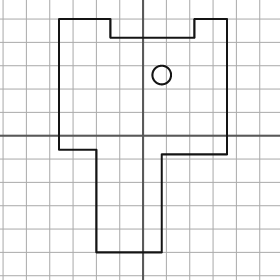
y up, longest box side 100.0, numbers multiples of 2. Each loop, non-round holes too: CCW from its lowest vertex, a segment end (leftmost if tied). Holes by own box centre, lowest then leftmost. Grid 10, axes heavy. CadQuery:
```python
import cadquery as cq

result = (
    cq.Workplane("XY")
    .moveTo(-20.0, -50.0)
    .lineTo(8.0, -50.0)
    .lineTo(8.0, -8.0)
    .lineTo(36.0, -8.0)
    .lineTo(36.0, 50.0)
    .lineTo(22.0, 50.0)
    .lineTo(22.0, 42.0)
    .lineTo(-14.0, 42.0)
    .lineTo(-14.0, 50.0)
    .lineTo(-36.0, 50.0)
    .lineTo(-36.0, -6.0)
    .lineTo(-20.0, -6.0)
    .close()
    .moveTo(8.0, 26.0)
    .circle(4.0)
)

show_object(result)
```